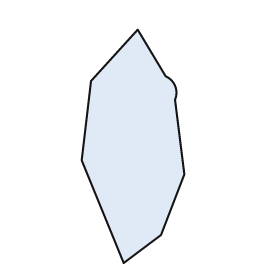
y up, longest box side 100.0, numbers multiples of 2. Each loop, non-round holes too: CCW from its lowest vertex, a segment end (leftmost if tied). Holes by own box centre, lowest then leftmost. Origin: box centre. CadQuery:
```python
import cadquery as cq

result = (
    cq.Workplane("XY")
    .moveTo(-4.0, -50.0)
    .lineTo(12.0, -38.0)
    .lineTo(22.0, -12.0)
    .lineTo(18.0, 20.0)
    .threePointArc((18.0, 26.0), (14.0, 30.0))
    .lineTo(2.0, 50.0)
    .lineTo(-18.0, 28.0)
    .lineTo(-22.0, -6.0)
    .close()
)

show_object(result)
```